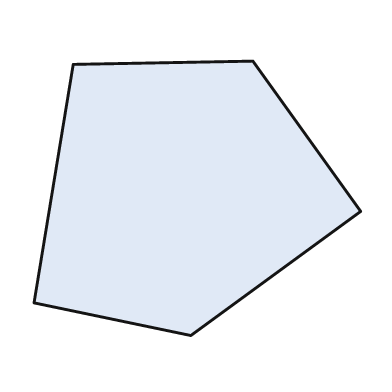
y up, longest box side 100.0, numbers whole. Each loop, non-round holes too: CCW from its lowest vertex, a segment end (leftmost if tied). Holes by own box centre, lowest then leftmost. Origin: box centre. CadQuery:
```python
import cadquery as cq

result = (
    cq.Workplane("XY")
    .moveTo(-2.0, -42.0)
    .lineTo(50.0, -4.0)
    .lineTo(17.0, 42.0)
    .lineTo(-38.0, 41.0)
    .lineTo(-50.0, -32.0)
    .close()
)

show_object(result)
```